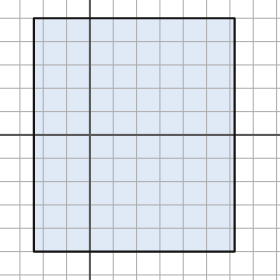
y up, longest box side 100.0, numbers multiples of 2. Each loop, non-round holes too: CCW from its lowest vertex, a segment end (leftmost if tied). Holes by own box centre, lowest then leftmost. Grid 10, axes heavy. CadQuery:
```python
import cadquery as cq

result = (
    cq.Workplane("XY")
    .moveTo(-24.0, -50.0)
    .lineTo(62.0, -50.0)
    .lineTo(62.0, 50.0)
    .lineTo(-24.0, 50.0)
    .close()
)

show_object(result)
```